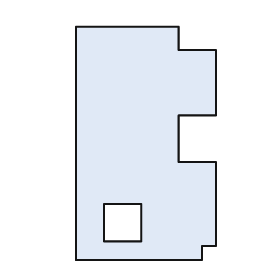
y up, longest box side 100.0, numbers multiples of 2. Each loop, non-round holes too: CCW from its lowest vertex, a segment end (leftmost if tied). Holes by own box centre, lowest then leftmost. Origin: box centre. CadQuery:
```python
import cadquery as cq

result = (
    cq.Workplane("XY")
    .moveTo(-30.0, -50.0)
    .lineTo(24.0, -50.0)
    .lineTo(24.0, -44.0)
    .lineTo(30.0, -44.0)
    .lineTo(30.0, -8.0)
    .lineTo(14.0, -8.0)
    .lineTo(14.0, 12.0)
    .lineTo(30.0, 12.0)
    .lineTo(30.0, 40.0)
    .lineTo(14.0, 40.0)
    .lineTo(14.0, 50.0)
    .lineTo(-30.0, 50.0)
    .close()
    .moveTo(-18.0, -42.0)
    .lineTo(-2.0, -42.0)
    .lineTo(-2.0, -26.0)
    .lineTo(-18.0, -26.0)
    .close()
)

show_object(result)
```